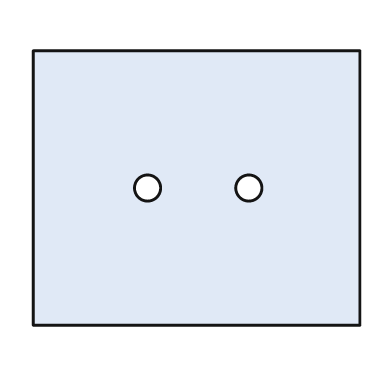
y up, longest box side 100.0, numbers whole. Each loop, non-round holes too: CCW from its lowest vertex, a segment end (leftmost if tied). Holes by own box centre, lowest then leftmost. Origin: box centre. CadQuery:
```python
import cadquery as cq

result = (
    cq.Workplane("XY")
    .moveTo(-50.0, -42.0)
    .lineTo(50.0, -42.0)
    .lineTo(50.0, 42.0)
    .lineTo(-50.0, 42.0)
    .close()
    .moveTo(-15.0, 0.0)
    .circle(4.0)
    .moveTo(16.0, 0.0)
    .circle(4.0)
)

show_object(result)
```